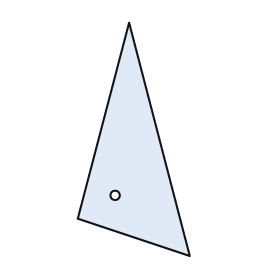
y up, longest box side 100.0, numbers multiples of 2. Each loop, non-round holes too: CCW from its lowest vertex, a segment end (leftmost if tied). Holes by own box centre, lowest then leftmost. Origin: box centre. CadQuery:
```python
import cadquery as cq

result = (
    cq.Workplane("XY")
    .moveTo(24.0, -50.0)
    .lineTo(-2.0, 50.0)
    .lineTo(-24.0, -34.0)
    .close()
    .moveTo(-8.0, -24.0)
    .circle(2.0)
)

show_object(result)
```